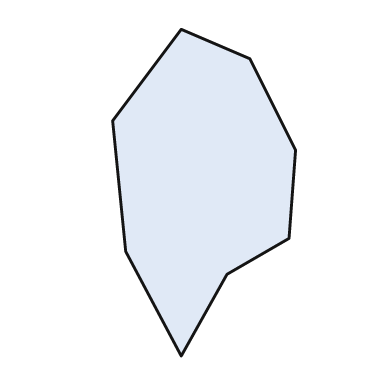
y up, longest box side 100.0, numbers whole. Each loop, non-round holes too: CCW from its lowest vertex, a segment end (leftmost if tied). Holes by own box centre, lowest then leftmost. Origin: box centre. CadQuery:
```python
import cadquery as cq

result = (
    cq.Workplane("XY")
    .moveTo(-7.0, -50.0)
    .lineTo(7.0, -25.0)
    .lineTo(26.0, -14.0)
    .lineTo(28.0, 13.0)
    .lineTo(14.0, 41.0)
    .lineTo(-7.0, 50.0)
    .lineTo(-28.0, 22.0)
    .lineTo(-24.0, -18.0)
    .close()
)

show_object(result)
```